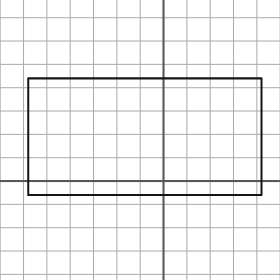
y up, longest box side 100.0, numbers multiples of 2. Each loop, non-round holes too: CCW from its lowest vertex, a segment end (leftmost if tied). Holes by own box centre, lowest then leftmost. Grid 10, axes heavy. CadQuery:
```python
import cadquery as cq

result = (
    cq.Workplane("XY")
    .moveTo(-58.0, -6.0)
    .lineTo(42.0, -6.0)
    .lineTo(42.0, 44.0)
    .lineTo(-58.0, 44.0)
    .close()
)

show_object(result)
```